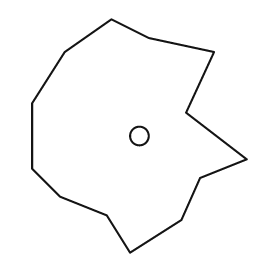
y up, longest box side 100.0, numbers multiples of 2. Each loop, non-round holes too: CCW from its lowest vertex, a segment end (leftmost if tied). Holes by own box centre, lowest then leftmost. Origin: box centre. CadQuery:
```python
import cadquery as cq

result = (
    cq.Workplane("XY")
    .moveTo(-4.0, -50.0)
    .lineTo(18.0, -36.0)
    .lineTo(26.0, -18.0)
    .lineTo(46.0, -10.0)
    .lineTo(20.0, 10.0)
    .lineTo(32.0, 36.0)
    .lineTo(4.0, 42.0)
    .lineTo(-12.0, 50.0)
    .lineTo(-32.0, 36.0)
    .lineTo(-46.0, 14.0)
    .lineTo(-46.0, -14.0)
    .lineTo(-34.0, -26.0)
    .lineTo(-14.0, -34.0)
    .close()
    .moveTo(0.0, 0.0)
    .circle(4.0)
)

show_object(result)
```